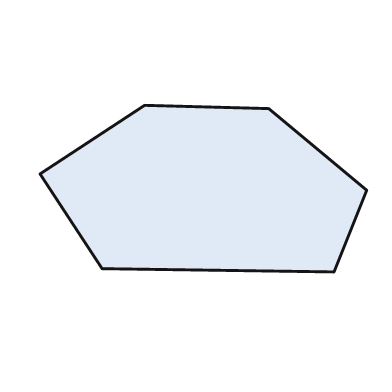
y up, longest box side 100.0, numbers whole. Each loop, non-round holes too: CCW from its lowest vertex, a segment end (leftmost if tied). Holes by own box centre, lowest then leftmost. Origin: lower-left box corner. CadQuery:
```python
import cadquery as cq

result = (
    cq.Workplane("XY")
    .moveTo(90.0, 0.0)
    .lineTo(100.0, 25.0)
    .lineTo(70.0, 50.0)
    .lineTo(32.0, 51.0)
    .lineTo(0.0, 30.0)
    .lineTo(19.0, 1.0)
    .close()
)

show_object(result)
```